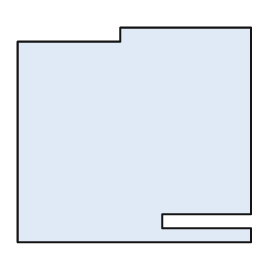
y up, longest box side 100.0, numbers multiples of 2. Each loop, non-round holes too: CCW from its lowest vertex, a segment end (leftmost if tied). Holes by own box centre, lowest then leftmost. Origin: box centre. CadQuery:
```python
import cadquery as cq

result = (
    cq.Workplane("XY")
    .moveTo(-50.0, -46.0)
    .lineTo(50.0, -46.0)
    .lineTo(50.0, -40.0)
    .lineTo(12.0, -40.0)
    .lineTo(12.0, -34.0)
    .lineTo(50.0, -34.0)
    .lineTo(50.0, 46.0)
    .lineTo(-6.0, 46.0)
    .lineTo(-6.0, 40.0)
    .lineTo(-50.0, 40.0)
    .close()
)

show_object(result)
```